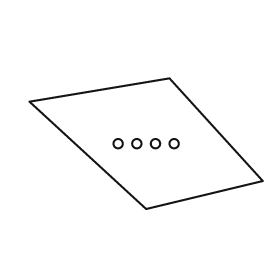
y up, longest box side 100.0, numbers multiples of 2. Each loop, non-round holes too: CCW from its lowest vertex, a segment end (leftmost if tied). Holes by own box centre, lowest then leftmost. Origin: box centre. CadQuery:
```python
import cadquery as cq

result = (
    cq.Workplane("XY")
    .moveTo(0.0, -28.0)
    .lineTo(50.0, -16.0)
    .lineTo(10.0, 28.0)
    .lineTo(-50.0, 18.0)
    .close()
    .moveTo(-12.0, 0.0)
    .circle(2.0)
    .moveTo(-4.0, 0.0)
    .circle(2.0)
    .moveTo(4.0, 0.0)
    .circle(2.0)
    .moveTo(12.0, 0.0)
    .circle(2.0)
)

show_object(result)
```